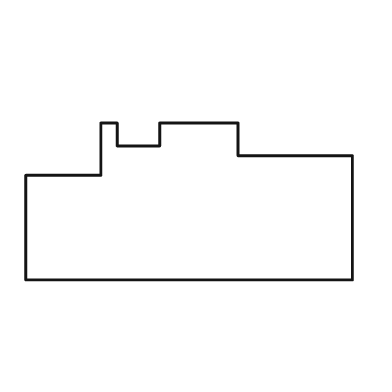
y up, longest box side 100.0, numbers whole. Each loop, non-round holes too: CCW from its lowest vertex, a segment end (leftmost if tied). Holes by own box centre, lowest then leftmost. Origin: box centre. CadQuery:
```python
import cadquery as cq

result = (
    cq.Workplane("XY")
    .moveTo(-50.0, -24.0)
    .lineTo(50.0, -24.0)
    .lineTo(50.0, 14.0)
    .lineTo(15.0, 14.0)
    .lineTo(15.0, 24.0)
    .lineTo(-9.0, 24.0)
    .lineTo(-9.0, 17.0)
    .lineTo(-22.0, 17.0)
    .lineTo(-22.0, 24.0)
    .lineTo(-27.0, 24.0)
    .lineTo(-27.0, 8.0)
    .lineTo(-50.0, 8.0)
    .close()
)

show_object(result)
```